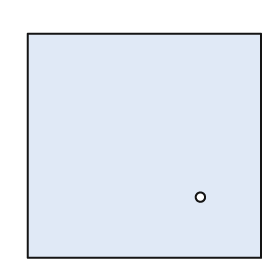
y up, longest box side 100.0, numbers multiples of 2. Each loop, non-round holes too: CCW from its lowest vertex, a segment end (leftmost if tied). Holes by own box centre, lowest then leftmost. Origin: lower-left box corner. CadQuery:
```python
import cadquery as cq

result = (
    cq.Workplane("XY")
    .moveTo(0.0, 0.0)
    .lineTo(100.0, 0.0)
    .lineTo(100.0, 96.0)
    .lineTo(0.0, 96.0)
    .close()
    .moveTo(74.0, 26.0)
    .circle(2.0)
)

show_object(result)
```